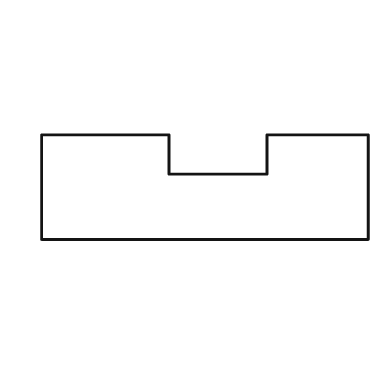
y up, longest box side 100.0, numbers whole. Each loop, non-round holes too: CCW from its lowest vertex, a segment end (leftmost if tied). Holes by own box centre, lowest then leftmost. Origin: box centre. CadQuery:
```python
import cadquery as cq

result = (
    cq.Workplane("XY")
    .moveTo(-50.0, -16.0)
    .lineTo(50.0, -16.0)
    .lineTo(50.0, 16.0)
    .lineTo(19.0, 16.0)
    .lineTo(19.0, 4.0)
    .lineTo(-11.0, 4.0)
    .lineTo(-11.0, 16.0)
    .lineTo(-50.0, 16.0)
    .close()
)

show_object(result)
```